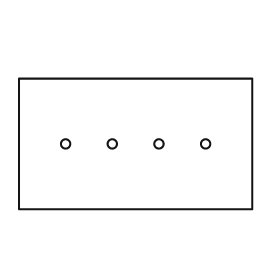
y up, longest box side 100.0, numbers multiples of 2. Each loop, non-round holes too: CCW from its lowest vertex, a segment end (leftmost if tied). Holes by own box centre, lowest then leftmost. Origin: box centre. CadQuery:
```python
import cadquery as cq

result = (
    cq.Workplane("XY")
    .moveTo(-50.0, -28.0)
    .lineTo(50.0, -28.0)
    .lineTo(50.0, 28.0)
    .lineTo(-50.0, 28.0)
    .close()
    .moveTo(-30.0, 0.0)
    .circle(2.0)
    .moveTo(-10.0, 0.0)
    .circle(2.0)
    .moveTo(10.0, 0.0)
    .circle(2.0)
    .moveTo(30.0, 0.0)
    .circle(2.0)
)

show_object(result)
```